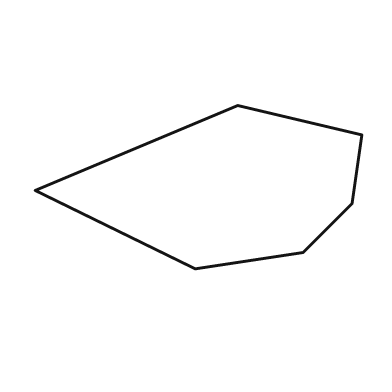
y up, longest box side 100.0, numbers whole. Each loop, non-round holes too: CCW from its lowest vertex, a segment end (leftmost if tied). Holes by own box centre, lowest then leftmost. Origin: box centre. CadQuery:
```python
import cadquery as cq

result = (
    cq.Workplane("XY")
    .moveTo(-1.0, -25.0)
    .lineTo(32.0, -20.0)
    .lineTo(47.0, -5.0)
    .lineTo(50.0, 16.0)
    .lineTo(12.0, 25.0)
    .lineTo(-50.0, -1.0)
    .close()
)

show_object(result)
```